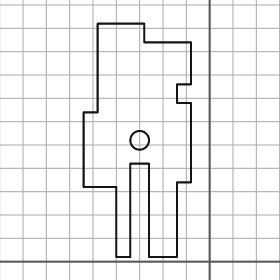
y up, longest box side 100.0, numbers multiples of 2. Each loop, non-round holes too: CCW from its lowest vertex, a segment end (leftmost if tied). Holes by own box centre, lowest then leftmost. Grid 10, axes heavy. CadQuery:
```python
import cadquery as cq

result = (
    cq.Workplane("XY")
    .moveTo(-40.0, 2.0)
    .lineTo(-34.0, 2.0)
    .lineTo(-34.0, 42.0)
    .lineTo(-26.0, 42.0)
    .lineTo(-26.0, 2.0)
    .lineTo(-14.0, 2.0)
    .lineTo(-14.0, 34.0)
    .lineTo(-8.0, 34.0)
    .lineTo(-8.0, 68.0)
    .lineTo(-14.0, 68.0)
    .lineTo(-14.0, 76.0)
    .lineTo(-8.0, 76.0)
    .lineTo(-8.0, 94.0)
    .lineTo(-28.0, 94.0)
    .lineTo(-28.0, 102.0)
    .lineTo(-48.0, 102.0)
    .lineTo(-48.0, 64.0)
    .lineTo(-54.0, 64.0)
    .lineTo(-54.0, 32.0)
    .lineTo(-40.0, 32.0)
    .close()
    .moveTo(-30.0, 52.0)
    .circle(4.0)
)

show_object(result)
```